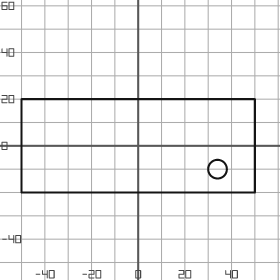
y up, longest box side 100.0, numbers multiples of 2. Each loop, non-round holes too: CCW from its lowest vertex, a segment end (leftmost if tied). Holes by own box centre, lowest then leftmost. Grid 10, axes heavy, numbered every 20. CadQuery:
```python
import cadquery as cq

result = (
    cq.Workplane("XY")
    .moveTo(-50.0, -20.0)
    .lineTo(50.0, -20.0)
    .lineTo(50.0, 20.0)
    .lineTo(-50.0, 20.0)
    .close()
    .moveTo(34.0, -10.0)
    .circle(4.0)
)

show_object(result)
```